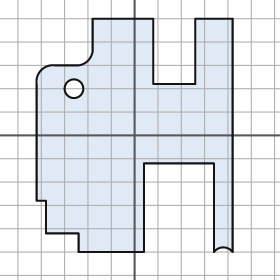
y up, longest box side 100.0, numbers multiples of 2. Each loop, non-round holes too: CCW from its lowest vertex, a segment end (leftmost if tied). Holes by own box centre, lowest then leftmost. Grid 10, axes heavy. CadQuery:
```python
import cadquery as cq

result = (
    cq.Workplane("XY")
    .moveTo(-24.0, -50.0)
    .lineTo(4.0, -50.0)
    .lineTo(4.0, -12.0)
    .lineTo(34.0, -12.0)
    .lineTo(34.0, -50.0)
    .threePointArc((38.0, -48.0), (42.0, -50.0))
    .lineTo(42.0, 50.0)
    .lineTo(26.0, 50.0)
    .lineTo(26.0, 22.0)
    .lineTo(8.0, 22.0)
    .lineTo(8.0, 50.0)
    .lineTo(-18.0, 50.0)
    .lineTo(-18.0, 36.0)
    .threePointArc((-20.0, 32.0), (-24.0, 30.0))
    .lineTo(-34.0, 30.0)
    .threePointArc((-40.0, 28.0), (-42.0, 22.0))
    .lineTo(-42.0, -28.0)
    .lineTo(-38.0, -28.0)
    .lineTo(-38.0, -42.0)
    .lineTo(-24.0, -42.0)
    .close()
    .moveTo(-26.0, 20.0)
    .circle(4.0)
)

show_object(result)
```